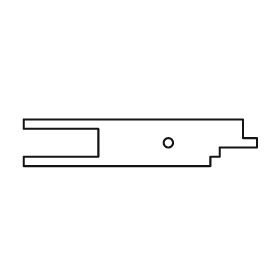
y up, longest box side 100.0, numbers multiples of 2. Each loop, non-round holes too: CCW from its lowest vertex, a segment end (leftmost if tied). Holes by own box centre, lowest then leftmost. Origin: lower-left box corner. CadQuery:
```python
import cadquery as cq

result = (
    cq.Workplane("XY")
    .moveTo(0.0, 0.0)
    .lineTo(80.0, 0.0)
    .lineTo(80.0, 4.0)
    .lineTo(84.0, 4.0)
    .lineTo(84.0, 8.0)
    .lineTo(100.0, 8.0)
    .lineTo(100.0, 12.0)
    .lineTo(94.0, 12.0)
    .lineTo(94.0, 20.0)
    .lineTo(0.0, 20.0)
    .lineTo(0.0, 16.0)
    .lineTo(32.0, 16.0)
    .lineTo(32.0, 4.0)
    .lineTo(0.0, 4.0)
    .close()
    .moveTo(62.0, 10.0)
    .circle(2.0)
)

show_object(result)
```